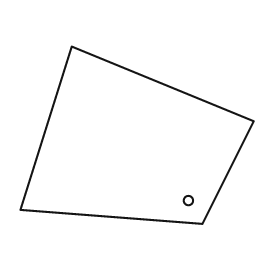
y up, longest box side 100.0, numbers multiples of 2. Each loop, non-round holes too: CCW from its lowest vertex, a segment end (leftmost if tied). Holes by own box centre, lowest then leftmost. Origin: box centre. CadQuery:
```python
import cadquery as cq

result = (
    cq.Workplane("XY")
    .moveTo(28.0, -38.0)
    .lineTo(50.0, 6.0)
    .lineTo(-28.0, 38.0)
    .lineTo(-50.0, -32.0)
    .close()
    .moveTo(22.0, -28.0)
    .circle(2.0)
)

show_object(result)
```